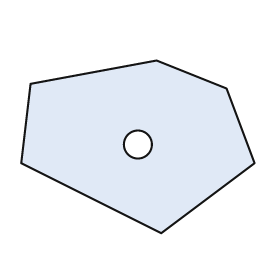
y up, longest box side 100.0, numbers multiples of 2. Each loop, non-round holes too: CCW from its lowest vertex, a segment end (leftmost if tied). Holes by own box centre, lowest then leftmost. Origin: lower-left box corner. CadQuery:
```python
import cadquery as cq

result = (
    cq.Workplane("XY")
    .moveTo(60.0, 0.0)
    .lineTo(100.0, 30.0)
    .lineTo(88.0, 62.0)
    .lineTo(58.0, 74.0)
    .lineTo(4.0, 64.0)
    .lineTo(0.0, 30.0)
    .close()
    .moveTo(50.0, 38.0)
    .circle(6.0)
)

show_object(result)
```